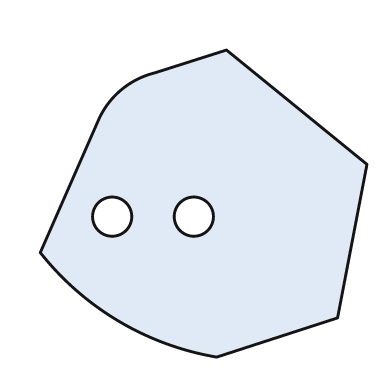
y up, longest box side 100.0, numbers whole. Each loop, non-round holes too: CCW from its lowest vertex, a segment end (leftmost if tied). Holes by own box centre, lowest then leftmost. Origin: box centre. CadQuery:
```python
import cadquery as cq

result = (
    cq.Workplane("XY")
    .moveTo(4.0, -47.0)
    .lineTo(41.0, -35.0)
    .lineTo(50.0, 12.0)
    .lineTo(7.0, 47.0)
    .lineTo(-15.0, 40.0)
    .threePointArc((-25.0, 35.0), (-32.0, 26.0))
    .lineTo(-50.0, -15.0)
    .threePointArc((-26.0, -36.0), (4.0, -47.0))
    .close()
    .moveTo(-28.0, -4.0)
    .circle(6.0)
    .moveTo(-3.0, -4.0)
    .circle(6.0)
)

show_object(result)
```